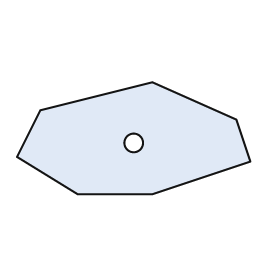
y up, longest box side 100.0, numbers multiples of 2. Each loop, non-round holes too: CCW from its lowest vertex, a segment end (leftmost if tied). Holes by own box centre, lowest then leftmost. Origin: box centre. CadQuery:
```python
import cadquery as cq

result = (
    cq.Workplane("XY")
    .moveTo(-24.0, -24.0)
    .lineTo(8.0, -24.0)
    .lineTo(50.0, -10.0)
    .lineTo(44.0, 8.0)
    .lineTo(8.0, 24.0)
    .lineTo(-40.0, 12.0)
    .lineTo(-50.0, -8.0)
    .close()
    .moveTo(0.0, -2.0)
    .circle(4.0)
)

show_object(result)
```